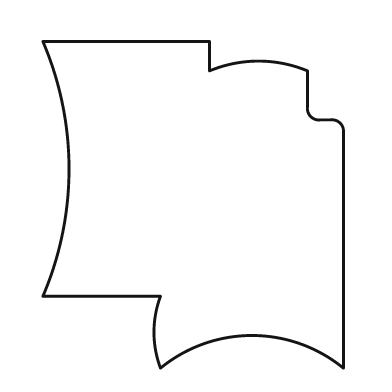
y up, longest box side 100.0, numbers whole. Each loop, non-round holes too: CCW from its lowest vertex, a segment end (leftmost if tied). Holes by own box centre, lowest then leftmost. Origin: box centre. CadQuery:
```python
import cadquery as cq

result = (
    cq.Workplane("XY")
    .moveTo(-10.0, -50.0)
    .threePointArc((18.0, -40.0), (46.0, -50.0))
    .lineTo(46.0, 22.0)
    .threePointArc((45.0, 25.0), (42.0, 26.0))
    .lineTo(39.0, 26.0)
    .threePointArc((36.0, 27.0), (35.0, 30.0))
    .lineTo(35.0, 41.0)
    .threePointArc((20.0, 44.0), (5.0, 41.0))
    .lineTo(5.0, 50.0)
    .lineTo(-46.0, 50.0)
    .threePointArc((-38.0, 11.0), (-46.0, -28.0))
    .lineTo(-10.0, -28.0)
    .threePointArc((-12.0, -39.0), (-10.0, -50.0))
    .close()
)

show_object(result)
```